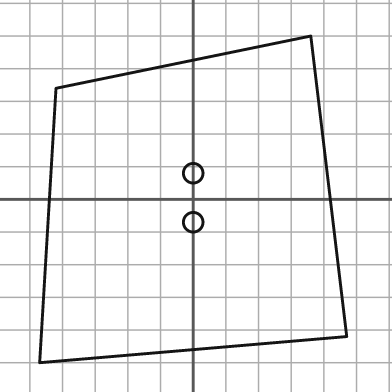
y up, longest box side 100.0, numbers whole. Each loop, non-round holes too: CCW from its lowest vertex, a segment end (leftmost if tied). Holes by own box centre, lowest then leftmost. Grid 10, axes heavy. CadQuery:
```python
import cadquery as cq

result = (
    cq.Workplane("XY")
    .moveTo(-47.0, -50.0)
    .lineTo(47.0, -42.0)
    .lineTo(36.0, 50.0)
    .lineTo(-42.0, 34.0)
    .close()
    .moveTo(0.0, -7.0)
    .circle(3.0)
    .moveTo(0.0, 8.0)
    .circle(3.0)
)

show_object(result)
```